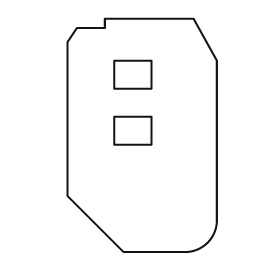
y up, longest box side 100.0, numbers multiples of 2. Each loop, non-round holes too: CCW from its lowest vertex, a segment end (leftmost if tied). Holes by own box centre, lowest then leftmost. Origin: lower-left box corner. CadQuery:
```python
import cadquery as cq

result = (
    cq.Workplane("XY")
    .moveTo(24.0, 0.0)
    .lineTo(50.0, 0.0)
    .threePointArc((60.0, 4.0), (64.0, 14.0))
    .lineTo(64.0, 82.0)
    .lineTo(54.0, 100.0)
    .lineTo(16.0, 100.0)
    .lineTo(16.0, 96.0)
    .lineTo(4.0, 96.0)
    .lineTo(0.0, 90.0)
    .lineTo(0.0, 24.0)
    .close()
    .moveTo(20.0, 46.0)
    .lineTo(36.0, 46.0)
    .lineTo(36.0, 58.0)
    .lineTo(20.0, 58.0)
    .close()
    .moveTo(20.0, 70.0)
    .lineTo(36.0, 70.0)
    .lineTo(36.0, 82.0)
    .lineTo(20.0, 82.0)
    .close()
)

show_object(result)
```